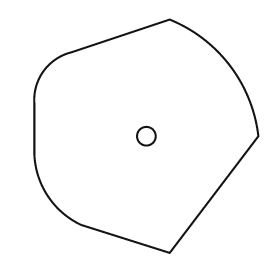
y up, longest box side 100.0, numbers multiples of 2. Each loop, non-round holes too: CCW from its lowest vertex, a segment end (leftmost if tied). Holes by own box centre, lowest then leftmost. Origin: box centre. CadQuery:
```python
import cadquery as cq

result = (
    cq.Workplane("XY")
    .moveTo(10.0, -50.0)
    .lineTo(48.0, 0.0)
    .threePointArc((36.0, 30.0), (10.0, 50.0))
    .lineTo(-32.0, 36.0)
    .threePointArc((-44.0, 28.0), (-48.0, 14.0))
    .lineTo(-48.0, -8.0)
    .threePointArc((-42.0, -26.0), (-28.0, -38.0))
    .close()
    .moveTo(0.0, 0.0)
    .circle(4.0)
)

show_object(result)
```